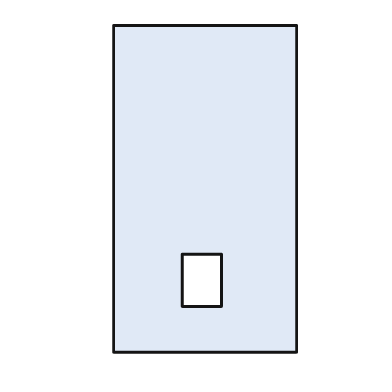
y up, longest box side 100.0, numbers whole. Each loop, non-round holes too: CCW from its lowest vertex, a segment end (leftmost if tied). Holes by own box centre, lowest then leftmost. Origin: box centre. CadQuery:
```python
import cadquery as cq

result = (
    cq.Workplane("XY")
    .moveTo(-28.0, -50.0)
    .lineTo(28.0, -50.0)
    .lineTo(28.0, 50.0)
    .lineTo(-28.0, 50.0)
    .close()
    .moveTo(-7.0, -36.0)
    .lineTo(5.0, -36.0)
    .lineTo(5.0, -20.0)
    .lineTo(-7.0, -20.0)
    .close()
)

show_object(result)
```